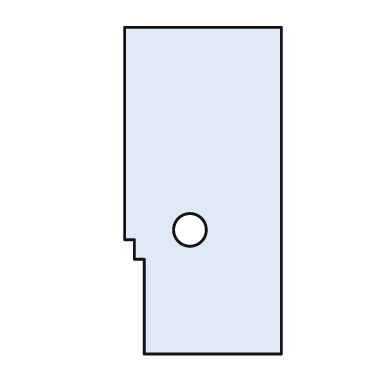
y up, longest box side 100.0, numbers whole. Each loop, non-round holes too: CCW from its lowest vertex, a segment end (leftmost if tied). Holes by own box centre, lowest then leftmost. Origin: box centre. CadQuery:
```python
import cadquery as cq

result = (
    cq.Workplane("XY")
    .moveTo(-18.0, -50.0)
    .lineTo(24.0, -50.0)
    .lineTo(24.0, 50.0)
    .lineTo(-24.0, 50.0)
    .lineTo(-24.0, -15.0)
    .lineTo(-21.0, -15.0)
    .lineTo(-21.0, -21.0)
    .lineTo(-18.0, -21.0)
    .close()
    .moveTo(-4.0, -12.0)
    .circle(5.0)
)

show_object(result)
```